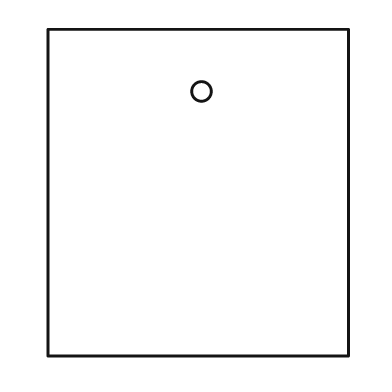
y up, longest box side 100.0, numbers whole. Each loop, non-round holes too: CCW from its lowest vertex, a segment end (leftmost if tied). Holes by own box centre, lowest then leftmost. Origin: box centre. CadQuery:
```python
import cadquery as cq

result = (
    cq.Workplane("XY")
    .moveTo(-46.0, -50.0)
    .lineTo(46.0, -50.0)
    .lineTo(46.0, 50.0)
    .lineTo(-46.0, 50.0)
    .close()
    .moveTo(1.0, 31.0)
    .circle(3.0)
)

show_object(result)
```